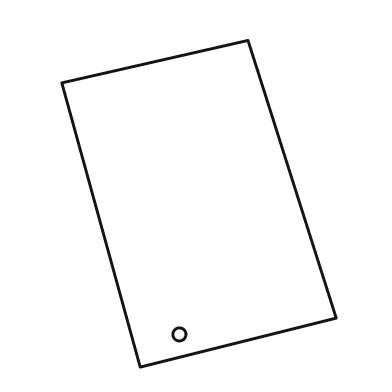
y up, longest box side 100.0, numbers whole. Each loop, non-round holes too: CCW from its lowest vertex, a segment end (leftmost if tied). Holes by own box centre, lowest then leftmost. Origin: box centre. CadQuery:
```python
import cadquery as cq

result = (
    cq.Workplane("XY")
    .moveTo(-18.0, -50.0)
    .lineTo(42.0, -35.0)
    .lineTo(15.0, 50.0)
    .lineTo(-42.0, 37.0)
    .close()
    .moveTo(-6.0, -40.0)
    .circle(2.0)
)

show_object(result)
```